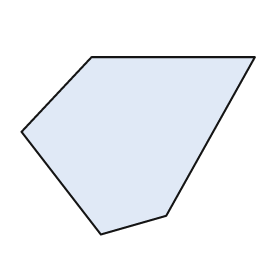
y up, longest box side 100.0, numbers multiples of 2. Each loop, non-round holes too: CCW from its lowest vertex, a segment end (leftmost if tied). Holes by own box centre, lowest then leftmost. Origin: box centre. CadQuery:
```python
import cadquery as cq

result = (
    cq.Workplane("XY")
    .moveTo(-16.0, -38.0)
    .lineTo(12.0, -30.0)
    .lineTo(50.0, 38.0)
    .lineTo(-20.0, 38.0)
    .lineTo(-50.0, 6.0)
    .close()
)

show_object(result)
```